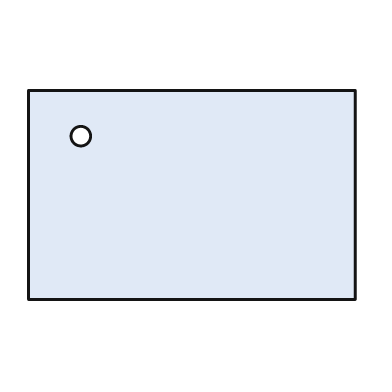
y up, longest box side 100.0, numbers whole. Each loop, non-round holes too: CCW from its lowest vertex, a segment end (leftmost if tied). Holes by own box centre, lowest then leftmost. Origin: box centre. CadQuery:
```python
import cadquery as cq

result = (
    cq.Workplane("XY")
    .moveTo(-50.0, -32.0)
    .lineTo(50.0, -32.0)
    .lineTo(50.0, 32.0)
    .lineTo(-50.0, 32.0)
    .close()
    .moveTo(-34.0, 18.0)
    .circle(3.0)
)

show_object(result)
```